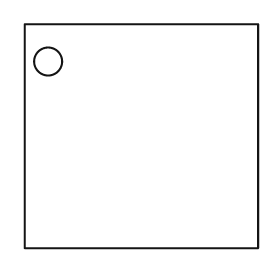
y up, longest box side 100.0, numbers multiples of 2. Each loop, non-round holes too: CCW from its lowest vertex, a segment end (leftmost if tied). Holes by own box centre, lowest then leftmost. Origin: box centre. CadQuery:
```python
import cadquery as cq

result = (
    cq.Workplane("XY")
    .moveTo(-50.0, -48.0)
    .lineTo(50.0, -48.0)
    .lineTo(50.0, 48.0)
    .lineTo(-50.0, 48.0)
    .close()
    .moveTo(-40.0, 32.0)
    .circle(6.0)
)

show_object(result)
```